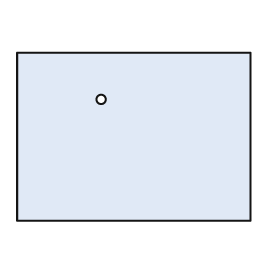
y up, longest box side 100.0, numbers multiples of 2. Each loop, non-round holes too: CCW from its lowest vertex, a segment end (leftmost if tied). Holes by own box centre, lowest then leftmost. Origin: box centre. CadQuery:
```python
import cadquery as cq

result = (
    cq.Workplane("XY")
    .moveTo(-50.0, -36.0)
    .lineTo(50.0, -36.0)
    .lineTo(50.0, 36.0)
    .lineTo(-50.0, 36.0)
    .close()
    .moveTo(-14.0, 16.0)
    .circle(2.0)
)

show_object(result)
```